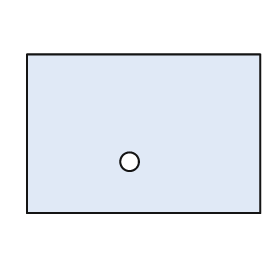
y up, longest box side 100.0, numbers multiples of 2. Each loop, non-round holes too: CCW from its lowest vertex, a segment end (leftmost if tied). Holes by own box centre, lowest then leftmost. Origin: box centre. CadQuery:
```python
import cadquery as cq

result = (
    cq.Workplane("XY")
    .moveTo(-50.0, -34.0)
    .lineTo(50.0, -34.0)
    .lineTo(50.0, 34.0)
    .lineTo(-50.0, 34.0)
    .close()
    .moveTo(-6.0, -12.0)
    .circle(4.0)
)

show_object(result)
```